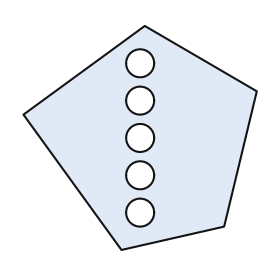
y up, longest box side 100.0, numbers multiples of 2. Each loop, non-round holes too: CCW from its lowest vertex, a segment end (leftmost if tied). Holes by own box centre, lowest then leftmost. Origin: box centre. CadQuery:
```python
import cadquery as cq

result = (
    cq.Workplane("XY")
    .moveTo(-8.0, -48.0)
    .lineTo(36.0, -38.0)
    .lineTo(50.0, 20.0)
    .lineTo(2.0, 48.0)
    .lineTo(-50.0, 10.0)
    .close()
    .moveTo(0.0, -32.0)
    .circle(6.0)
    .moveTo(0.0, -16.0)
    .circle(6.0)
    .moveTo(0.0, 0.0)
    .circle(6.0)
    .moveTo(0.0, 16.0)
    .circle(6.0)
    .moveTo(0.0, 32.0)
    .circle(6.0)
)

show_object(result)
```